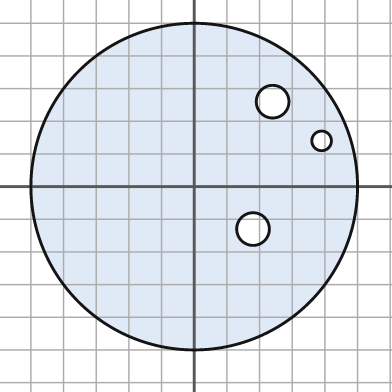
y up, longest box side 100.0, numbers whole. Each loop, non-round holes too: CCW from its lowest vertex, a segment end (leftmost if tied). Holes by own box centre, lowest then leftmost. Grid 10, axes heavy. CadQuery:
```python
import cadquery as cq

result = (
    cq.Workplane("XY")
    .moveTo(0.0, 0.0)
    .circle(50.0)
    .moveTo(18.0, -13.0)
    .circle(5.0)
    .moveTo(39.0, 14.0)
    .circle(3.0)
    .moveTo(24.0, 26.0)
    .circle(5.0)
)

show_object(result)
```